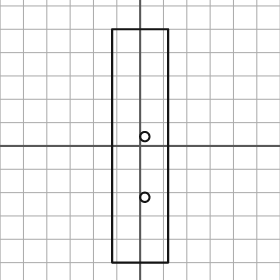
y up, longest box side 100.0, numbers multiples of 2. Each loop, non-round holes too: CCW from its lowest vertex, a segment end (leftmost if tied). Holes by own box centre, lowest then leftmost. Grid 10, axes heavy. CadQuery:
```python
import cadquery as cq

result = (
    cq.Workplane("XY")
    .moveTo(-12.0, -50.0)
    .lineTo(12.0, -50.0)
    .lineTo(12.0, 50.0)
    .lineTo(-12.0, 50.0)
    .close()
    .moveTo(2.0, -22.0)
    .circle(2.0)
    .moveTo(2.0, 4.0)
    .circle(2.0)
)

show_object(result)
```